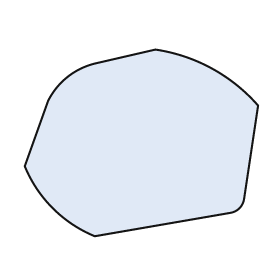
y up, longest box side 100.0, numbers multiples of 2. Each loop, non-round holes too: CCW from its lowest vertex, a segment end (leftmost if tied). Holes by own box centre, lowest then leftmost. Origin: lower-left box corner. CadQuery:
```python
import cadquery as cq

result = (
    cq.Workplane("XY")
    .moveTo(30.0, 0.0)
    .lineTo(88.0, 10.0)
    .threePointArc((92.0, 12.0), (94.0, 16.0))
    .lineTo(100.0, 56.0)
    .threePointArc((80.0, 72.0), (56.0, 80.0))
    .lineTo(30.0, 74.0)
    .threePointArc((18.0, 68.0), (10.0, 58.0))
    .lineTo(0.0, 30.0)
    .threePointArc((12.0, 12.0), (30.0, 0.0))
    .close()
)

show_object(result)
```